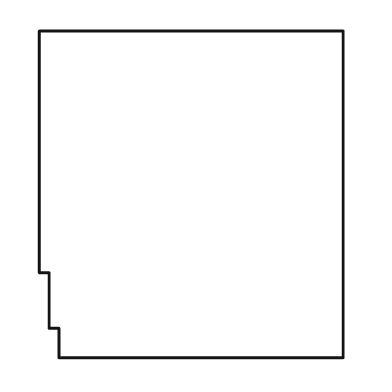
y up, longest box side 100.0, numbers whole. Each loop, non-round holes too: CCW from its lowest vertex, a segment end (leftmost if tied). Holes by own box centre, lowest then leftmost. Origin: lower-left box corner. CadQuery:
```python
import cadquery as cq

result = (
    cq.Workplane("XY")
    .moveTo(6.0, 0.0)
    .lineTo(93.0, 0.0)
    .lineTo(93.0, 100.0)
    .lineTo(0.0, 100.0)
    .lineTo(0.0, 26.0)
    .lineTo(3.0, 26.0)
    .lineTo(3.0, 9.0)
    .lineTo(6.0, 9.0)
    .close()
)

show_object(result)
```